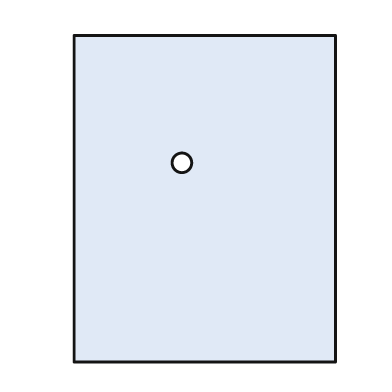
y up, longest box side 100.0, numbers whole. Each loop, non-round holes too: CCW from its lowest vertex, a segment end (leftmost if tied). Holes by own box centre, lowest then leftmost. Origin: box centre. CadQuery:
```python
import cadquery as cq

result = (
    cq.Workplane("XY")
    .moveTo(-40.0, -50.0)
    .lineTo(40.0, -50.0)
    .lineTo(40.0, 50.0)
    .lineTo(-40.0, 50.0)
    .close()
    .moveTo(-7.0, 11.0)
    .circle(3.0)
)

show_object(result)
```